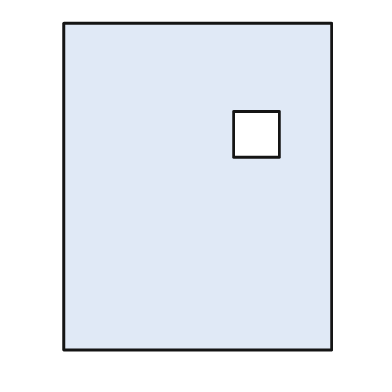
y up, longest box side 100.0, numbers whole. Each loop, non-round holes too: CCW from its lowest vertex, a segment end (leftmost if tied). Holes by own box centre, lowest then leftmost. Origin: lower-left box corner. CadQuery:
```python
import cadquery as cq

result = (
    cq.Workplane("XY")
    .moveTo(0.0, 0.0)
    .lineTo(82.0, 0.0)
    .lineTo(82.0, 100.0)
    .lineTo(0.0, 100.0)
    .close()
    .moveTo(52.0, 59.0)
    .lineTo(66.0, 59.0)
    .lineTo(66.0, 73.0)
    .lineTo(52.0, 73.0)
    .close()
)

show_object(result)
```